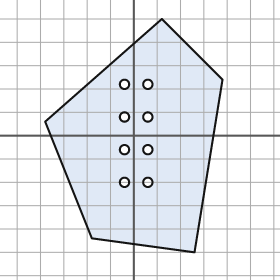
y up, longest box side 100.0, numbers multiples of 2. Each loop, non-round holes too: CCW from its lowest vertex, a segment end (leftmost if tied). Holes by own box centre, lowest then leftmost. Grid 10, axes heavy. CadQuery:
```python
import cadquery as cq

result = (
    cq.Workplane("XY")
    .moveTo(26.0, -50.0)
    .lineTo(38.0, 24.0)
    .lineTo(12.0, 50.0)
    .lineTo(-38.0, 6.0)
    .lineTo(-18.0, -44.0)
    .close()
    .moveTo(-4.0, -20.0)
    .circle(2.0)
    .moveTo(6.0, -20.0)
    .circle(2.0)
    .moveTo(-4.0, -6.0)
    .circle(2.0)
    .moveTo(6.0, -6.0)
    .circle(2.0)
    .moveTo(-4.0, 8.0)
    .circle(2.0)
    .moveTo(6.0, 8.0)
    .circle(2.0)
    .moveTo(-4.0, 22.0)
    .circle(2.0)
    .moveTo(6.0, 22.0)
    .circle(2.0)
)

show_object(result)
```